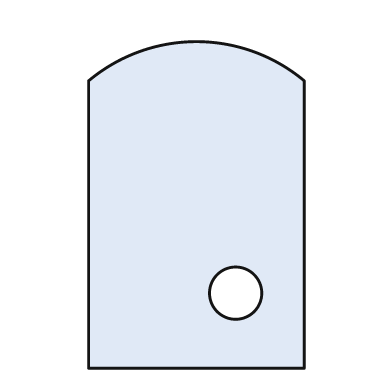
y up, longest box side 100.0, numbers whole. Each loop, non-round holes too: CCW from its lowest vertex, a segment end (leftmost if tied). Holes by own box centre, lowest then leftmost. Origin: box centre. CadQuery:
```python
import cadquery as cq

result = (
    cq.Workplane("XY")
    .moveTo(-33.0, -50.0)
    .lineTo(33.0, -50.0)
    .lineTo(33.0, 38.0)
    .threePointArc((0.0, 50.0), (-33.0, 38.0))
    .close()
    .moveTo(12.0, -27.0)
    .circle(8.0)
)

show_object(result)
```